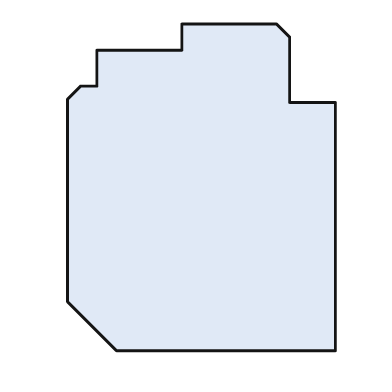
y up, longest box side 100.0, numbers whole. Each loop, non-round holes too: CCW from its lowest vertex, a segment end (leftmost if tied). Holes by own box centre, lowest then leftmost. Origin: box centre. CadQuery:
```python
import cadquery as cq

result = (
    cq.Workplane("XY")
    .moveTo(-26.0, -50.0)
    .lineTo(41.0, -50.0)
    .lineTo(41.0, 26.0)
    .lineTo(27.0, 26.0)
    .lineTo(27.0, 46.0)
    .lineTo(23.0, 50.0)
    .lineTo(-6.0, 50.0)
    .lineTo(-6.0, 42.0)
    .lineTo(-32.0, 42.0)
    .lineTo(-32.0, 31.0)
    .lineTo(-37.0, 31.0)
    .lineTo(-41.0, 27.0)
    .lineTo(-41.0, -35.0)
    .close()
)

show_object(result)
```